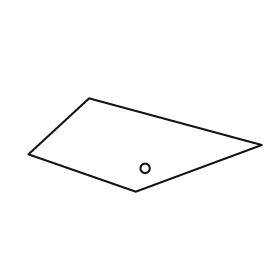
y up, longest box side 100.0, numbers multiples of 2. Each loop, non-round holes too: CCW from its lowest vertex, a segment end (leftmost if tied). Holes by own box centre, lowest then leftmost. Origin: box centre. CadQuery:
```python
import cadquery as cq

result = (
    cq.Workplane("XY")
    .moveTo(-4.0, -20.0)
    .lineTo(50.0, 0.0)
    .lineTo(-24.0, 20.0)
    .lineTo(-50.0, -4.0)
    .close()
    .moveTo(0.0, -10.0)
    .circle(2.0)
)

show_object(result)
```